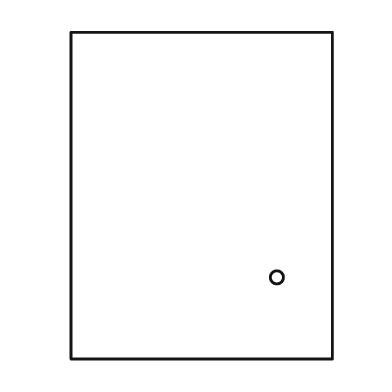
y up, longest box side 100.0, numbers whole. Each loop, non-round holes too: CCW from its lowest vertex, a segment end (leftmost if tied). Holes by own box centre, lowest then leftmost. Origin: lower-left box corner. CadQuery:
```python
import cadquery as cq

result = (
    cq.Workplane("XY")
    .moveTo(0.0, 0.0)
    .lineTo(80.0, 0.0)
    .lineTo(80.0, 100.0)
    .lineTo(0.0, 100.0)
    .close()
    .moveTo(63.0, 25.0)
    .circle(2.0)
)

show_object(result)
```